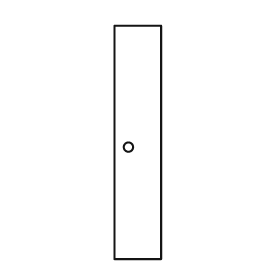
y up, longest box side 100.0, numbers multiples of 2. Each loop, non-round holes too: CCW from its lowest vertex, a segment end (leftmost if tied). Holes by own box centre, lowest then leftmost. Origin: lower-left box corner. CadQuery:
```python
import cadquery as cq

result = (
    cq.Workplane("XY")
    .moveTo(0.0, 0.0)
    .lineTo(20.0, 0.0)
    .lineTo(20.0, 100.0)
    .lineTo(0.0, 100.0)
    .close()
    .moveTo(6.0, 48.0)
    .circle(2.0)
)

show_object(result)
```